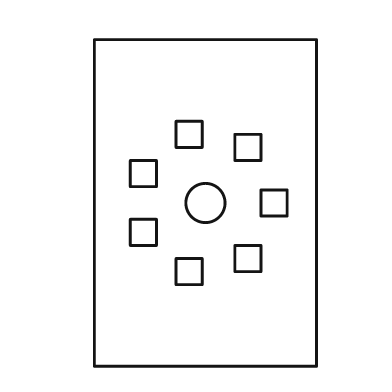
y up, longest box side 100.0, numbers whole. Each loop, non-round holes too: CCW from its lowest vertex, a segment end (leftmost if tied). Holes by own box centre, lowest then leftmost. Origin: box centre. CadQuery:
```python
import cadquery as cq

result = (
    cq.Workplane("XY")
    .moveTo(-34.0, -50.0)
    .lineTo(34.0, -50.0)
    .lineTo(34.0, 50.0)
    .lineTo(-34.0, 50.0)
    .close()
    .moveTo(-9.0, -25.0)
    .lineTo(-1.0, -25.0)
    .lineTo(-1.0, -17.0)
    .lineTo(-9.0, -17.0)
    .close()
    .moveTo(9.0, -21.0)
    .lineTo(17.0, -21.0)
    .lineTo(17.0, -13.0)
    .lineTo(9.0, -13.0)
    .close()
    .moveTo(-23.0, -13.0)
    .lineTo(-15.0, -13.0)
    .lineTo(-15.0, -5.0)
    .lineTo(-23.0, -5.0)
    .close()
    .moveTo(0.0, 0.0)
    .circle(6.0)
    .moveTo(17.0, -4.0)
    .lineTo(25.0, -4.0)
    .lineTo(25.0, 4.0)
    .lineTo(17.0, 4.0)
    .close()
    .moveTo(-23.0, 5.0)
    .lineTo(-15.0, 5.0)
    .lineTo(-15.0, 13.0)
    .lineTo(-23.0, 13.0)
    .close()
    .moveTo(9.0, 13.0)
    .lineTo(17.0, 13.0)
    .lineTo(17.0, 21.0)
    .lineTo(9.0, 21.0)
    .close()
    .moveTo(-9.0, 17.0)
    .lineTo(-1.0, 17.0)
    .lineTo(-1.0, 25.0)
    .lineTo(-9.0, 25.0)
    .close()
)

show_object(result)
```